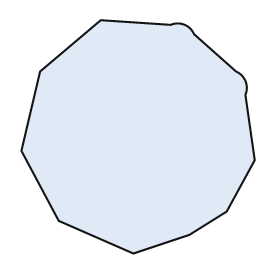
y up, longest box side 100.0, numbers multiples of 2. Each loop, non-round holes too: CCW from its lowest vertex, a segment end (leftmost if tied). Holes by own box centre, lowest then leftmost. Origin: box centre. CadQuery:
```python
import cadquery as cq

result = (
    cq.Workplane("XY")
    .moveTo(-2.0, -50.0)
    .lineTo(22.0, -42.0)
    .lineTo(38.0, -32.0)
    .lineTo(50.0, -10.0)
    .lineTo(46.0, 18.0)
    .threePointArc((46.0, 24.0), (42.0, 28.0))
    .lineTo(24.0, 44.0)
    .threePointArc((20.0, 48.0), (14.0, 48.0))
    .lineTo(-16.0, 50.0)
    .lineTo(-42.0, 28.0)
    .lineTo(-50.0, -6.0)
    .lineTo(-34.0, -36.0)
    .close()
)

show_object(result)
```